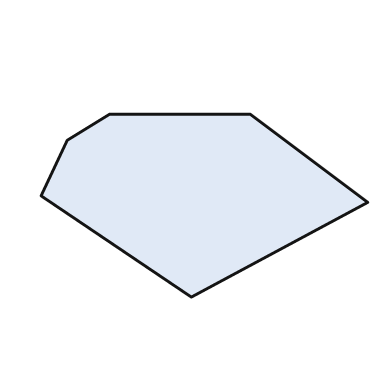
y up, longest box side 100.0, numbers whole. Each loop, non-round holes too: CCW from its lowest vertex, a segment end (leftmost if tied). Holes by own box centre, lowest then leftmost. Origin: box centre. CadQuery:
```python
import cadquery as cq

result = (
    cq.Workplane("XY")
    .moveTo(-4.0, -28.0)
    .lineTo(50.0, 1.0)
    .lineTo(14.0, 28.0)
    .lineTo(-29.0, 28.0)
    .lineTo(-42.0, 20.0)
    .lineTo(-50.0, 3.0)
    .close()
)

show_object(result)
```